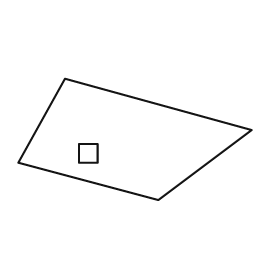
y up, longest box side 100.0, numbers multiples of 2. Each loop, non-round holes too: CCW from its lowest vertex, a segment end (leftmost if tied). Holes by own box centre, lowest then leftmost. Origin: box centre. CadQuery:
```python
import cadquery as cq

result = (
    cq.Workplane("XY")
    .moveTo(10.0, -26.0)
    .lineTo(50.0, 4.0)
    .lineTo(-30.0, 26.0)
    .lineTo(-50.0, -10.0)
    .close()
    .moveTo(-24.0, -10.0)
    .lineTo(-16.0, -10.0)
    .lineTo(-16.0, -2.0)
    .lineTo(-24.0, -2.0)
    .close()
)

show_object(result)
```